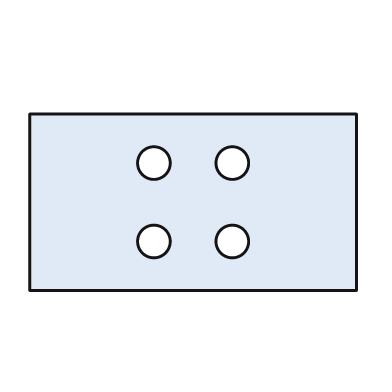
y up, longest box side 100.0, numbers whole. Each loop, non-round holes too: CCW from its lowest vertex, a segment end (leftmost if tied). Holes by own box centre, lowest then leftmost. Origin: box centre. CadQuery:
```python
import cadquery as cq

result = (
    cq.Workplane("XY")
    .moveTo(-50.0, -27.0)
    .lineTo(50.0, -27.0)
    .lineTo(50.0, 27.0)
    .lineTo(-50.0, 27.0)
    .close()
    .moveTo(-12.0, -12.0)
    .circle(5.0)
    .moveTo(12.0, -12.0)
    .circle(5.0)
    .moveTo(-12.0, 12.0)
    .circle(5.0)
    .moveTo(12.0, 12.0)
    .circle(5.0)
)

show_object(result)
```